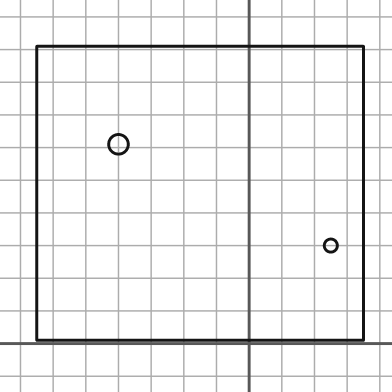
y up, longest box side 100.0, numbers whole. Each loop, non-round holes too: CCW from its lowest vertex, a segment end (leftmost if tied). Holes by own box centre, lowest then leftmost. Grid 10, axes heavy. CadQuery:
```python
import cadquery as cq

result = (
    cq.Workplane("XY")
    .moveTo(-65.0, 1.0)
    .lineTo(35.0, 1.0)
    .lineTo(35.0, 91.0)
    .lineTo(-65.0, 91.0)
    .close()
    .moveTo(25.0, 30.0)
    .circle(2.0)
    .moveTo(-40.0, 61.0)
    .circle(3.0)
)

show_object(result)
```